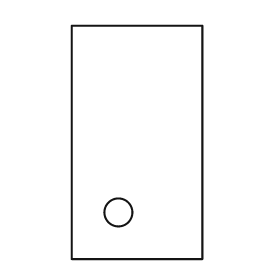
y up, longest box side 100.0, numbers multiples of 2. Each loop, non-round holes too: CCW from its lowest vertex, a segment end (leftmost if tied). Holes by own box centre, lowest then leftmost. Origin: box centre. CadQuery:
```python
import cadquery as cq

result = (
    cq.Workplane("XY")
    .moveTo(-28.0, -50.0)
    .lineTo(28.0, -50.0)
    .lineTo(28.0, 50.0)
    .lineTo(-28.0, 50.0)
    .close()
    .moveTo(-8.0, -30.0)
    .circle(6.0)
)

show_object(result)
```